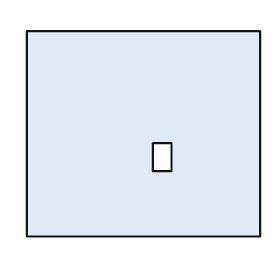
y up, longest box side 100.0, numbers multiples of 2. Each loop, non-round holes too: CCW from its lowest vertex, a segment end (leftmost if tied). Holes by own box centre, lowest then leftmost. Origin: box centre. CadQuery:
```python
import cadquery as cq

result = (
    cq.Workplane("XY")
    .moveTo(-50.0, -44.0)
    .lineTo(50.0, -44.0)
    .lineTo(50.0, 44.0)
    .lineTo(-50.0, 44.0)
    .close()
    .moveTo(4.0, -16.0)
    .lineTo(12.0, -16.0)
    .lineTo(12.0, -4.0)
    .lineTo(4.0, -4.0)
    .close()
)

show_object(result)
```